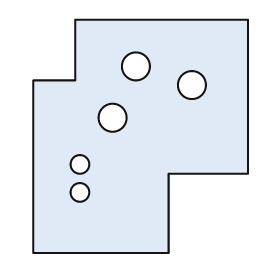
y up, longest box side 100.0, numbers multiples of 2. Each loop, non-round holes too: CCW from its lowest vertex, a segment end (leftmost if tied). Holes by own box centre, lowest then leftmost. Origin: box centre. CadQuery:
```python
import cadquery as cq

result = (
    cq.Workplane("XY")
    .moveTo(-46.0, -50.0)
    .lineTo(12.0, -50.0)
    .lineTo(12.0, -16.0)
    .lineTo(46.0, -16.0)
    .lineTo(46.0, 50.0)
    .lineTo(-28.0, 50.0)
    .lineTo(-28.0, 24.0)
    .lineTo(-46.0, 24.0)
    .close()
    .moveTo(-26.0, -24.0)
    .circle(4.0)
    .moveTo(-26.0, -12.0)
    .circle(4.0)
    .moveTo(-12.0, 8.0)
    .circle(6.0)
    .moveTo(22.0, 22.0)
    .circle(6.0)
    .moveTo(-2.0, 30.0)
    .circle(6.0)
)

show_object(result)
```